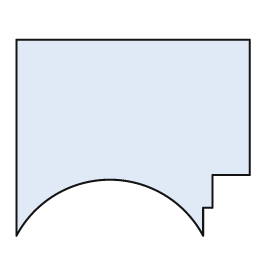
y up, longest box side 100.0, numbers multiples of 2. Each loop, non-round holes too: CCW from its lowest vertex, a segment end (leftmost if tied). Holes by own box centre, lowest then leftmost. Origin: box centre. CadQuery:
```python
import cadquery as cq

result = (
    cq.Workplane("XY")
    .moveTo(-50.0, -42.0)
    .threePointArc((-10.0, -18.0), (30.0, -42.0))
    .lineTo(30.0, -30.0)
    .lineTo(34.0, -30.0)
    .lineTo(34.0, -16.0)
    .lineTo(50.0, -16.0)
    .lineTo(50.0, 42.0)
    .lineTo(-50.0, 42.0)
    .close()
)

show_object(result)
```